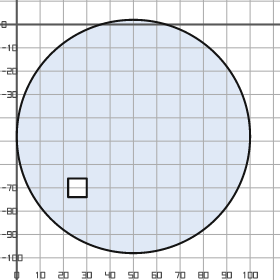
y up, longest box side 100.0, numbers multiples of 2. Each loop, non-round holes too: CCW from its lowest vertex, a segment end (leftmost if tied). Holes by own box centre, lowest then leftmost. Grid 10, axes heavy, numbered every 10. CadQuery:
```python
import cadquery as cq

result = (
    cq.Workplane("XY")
    .moveTo(50.0, -48.0)
    .circle(50.0)
    .moveTo(22.0, -74.0)
    .lineTo(30.0, -74.0)
    .lineTo(30.0, -66.0)
    .lineTo(22.0, -66.0)
    .close()
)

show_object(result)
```